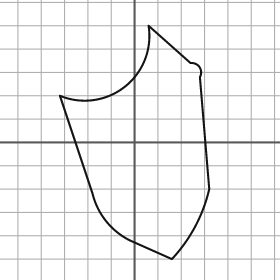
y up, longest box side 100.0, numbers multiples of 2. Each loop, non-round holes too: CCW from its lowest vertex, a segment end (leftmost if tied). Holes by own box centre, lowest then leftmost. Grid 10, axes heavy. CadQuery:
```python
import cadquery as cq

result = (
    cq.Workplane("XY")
    .moveTo(16.0, -50.0)
    .threePointArc((26.0, -36.0), (32.0, -20.0))
    .lineTo(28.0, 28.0)
    .threePointArc((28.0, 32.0), (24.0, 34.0))
    .lineTo(6.0, 50.0)
    .threePointArc((-4.0, 24.0), (-32.0, 20.0))
    .lineTo(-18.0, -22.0)
    .threePointArc((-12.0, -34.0), (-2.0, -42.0))
    .close()
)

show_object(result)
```